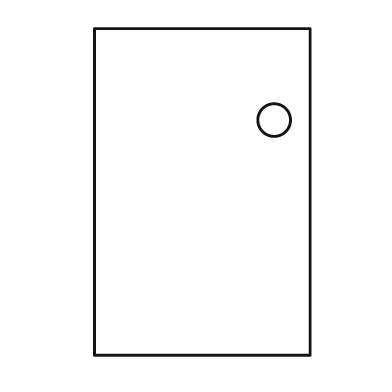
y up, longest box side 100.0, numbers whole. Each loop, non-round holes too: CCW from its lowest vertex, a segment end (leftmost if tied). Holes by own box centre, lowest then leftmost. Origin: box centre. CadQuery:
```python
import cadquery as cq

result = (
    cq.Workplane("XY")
    .moveTo(-33.0, -50.0)
    .lineTo(33.0, -50.0)
    .lineTo(33.0, 50.0)
    .lineTo(-33.0, 50.0)
    .close()
    .moveTo(22.0, 22.0)
    .circle(5.0)
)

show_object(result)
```